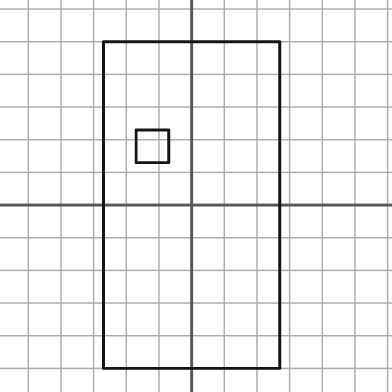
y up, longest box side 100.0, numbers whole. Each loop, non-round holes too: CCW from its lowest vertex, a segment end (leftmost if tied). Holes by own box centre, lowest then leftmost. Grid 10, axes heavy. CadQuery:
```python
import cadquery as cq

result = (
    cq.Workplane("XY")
    .moveTo(-27.0, -50.0)
    .lineTo(27.0, -50.0)
    .lineTo(27.0, 50.0)
    .lineTo(-27.0, 50.0)
    .close()
    .moveTo(-17.0, 13.0)
    .lineTo(-7.0, 13.0)
    .lineTo(-7.0, 23.0)
    .lineTo(-17.0, 23.0)
    .close()
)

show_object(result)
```